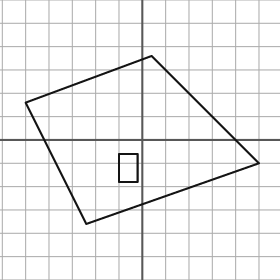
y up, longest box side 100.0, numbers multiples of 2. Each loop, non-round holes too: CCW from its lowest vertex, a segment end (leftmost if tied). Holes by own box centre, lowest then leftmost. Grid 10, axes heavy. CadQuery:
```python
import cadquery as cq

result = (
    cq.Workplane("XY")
    .moveTo(-24.0, -36.0)
    .lineTo(50.0, -10.0)
    .lineTo(4.0, 36.0)
    .lineTo(-50.0, 16.0)
    .close()
    .moveTo(-10.0, -18.0)
    .lineTo(-2.0, -18.0)
    .lineTo(-2.0, -6.0)
    .lineTo(-10.0, -6.0)
    .close()
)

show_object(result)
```